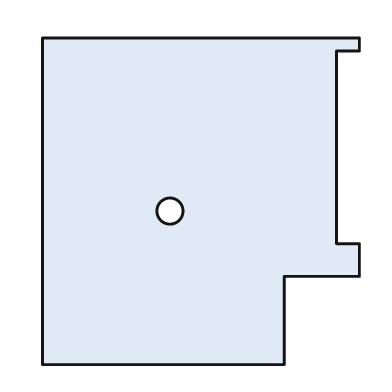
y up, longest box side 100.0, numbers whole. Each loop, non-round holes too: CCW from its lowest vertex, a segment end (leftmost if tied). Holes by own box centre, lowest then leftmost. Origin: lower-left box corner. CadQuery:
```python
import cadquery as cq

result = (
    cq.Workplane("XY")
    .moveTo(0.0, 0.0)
    .lineTo(74.0, 0.0)
    .lineTo(74.0, 27.0)
    .lineTo(97.0, 27.0)
    .lineTo(97.0, 37.0)
    .lineTo(90.0, 37.0)
    .lineTo(90.0, 96.0)
    .lineTo(97.0, 96.0)
    .lineTo(97.0, 100.0)
    .lineTo(0.0, 100.0)
    .close()
    .moveTo(39.0, 47.0)
    .circle(4.0)
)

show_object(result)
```